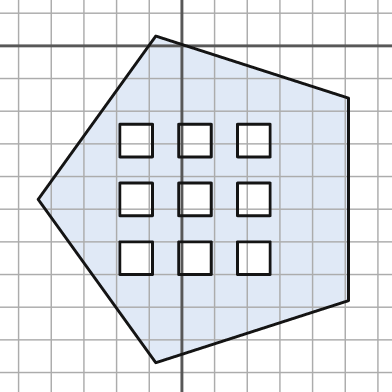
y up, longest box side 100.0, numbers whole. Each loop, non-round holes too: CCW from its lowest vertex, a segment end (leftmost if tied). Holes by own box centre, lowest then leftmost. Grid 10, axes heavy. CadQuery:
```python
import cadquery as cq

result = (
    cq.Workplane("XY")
    .moveTo(-8.0, -97.0)
    .lineTo(51.0, -78.0)
    .lineTo(51.0, -16.0)
    .lineTo(-8.0, 3.0)
    .lineTo(-44.0, -47.0)
    .close()
    .moveTo(-19.0, -70.0)
    .lineTo(-9.0, -70.0)
    .lineTo(-9.0, -60.0)
    .lineTo(-19.0, -60.0)
    .close()
    .moveTo(-1.0, -70.0)
    .lineTo(9.0, -70.0)
    .lineTo(9.0, -60.0)
    .lineTo(-1.0, -60.0)
    .close()
    .moveTo(17.0, -70.0)
    .lineTo(27.0, -70.0)
    .lineTo(27.0, -60.0)
    .lineTo(17.0, -60.0)
    .close()
    .moveTo(-19.0, -52.0)
    .lineTo(-9.0, -52.0)
    .lineTo(-9.0, -42.0)
    .lineTo(-19.0, -42.0)
    .close()
    .moveTo(-1.0, -52.0)
    .lineTo(9.0, -52.0)
    .lineTo(9.0, -42.0)
    .lineTo(-1.0, -42.0)
    .close()
    .moveTo(17.0, -52.0)
    .lineTo(27.0, -52.0)
    .lineTo(27.0, -42.0)
    .lineTo(17.0, -42.0)
    .close()
    .moveTo(-19.0, -34.0)
    .lineTo(-9.0, -34.0)
    .lineTo(-9.0, -24.0)
    .lineTo(-19.0, -24.0)
    .close()
    .moveTo(-1.0, -34.0)
    .lineTo(9.0, -34.0)
    .lineTo(9.0, -24.0)
    .lineTo(-1.0, -24.0)
    .close()
    .moveTo(17.0, -34.0)
    .lineTo(27.0, -34.0)
    .lineTo(27.0, -24.0)
    .lineTo(17.0, -24.0)
    .close()
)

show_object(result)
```